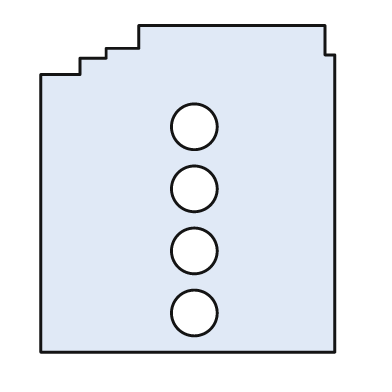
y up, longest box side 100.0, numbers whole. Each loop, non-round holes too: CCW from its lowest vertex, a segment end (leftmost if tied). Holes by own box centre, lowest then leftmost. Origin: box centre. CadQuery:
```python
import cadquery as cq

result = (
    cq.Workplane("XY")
    .moveTo(-45.0, -50.0)
    .lineTo(45.0, -50.0)
    .lineTo(45.0, 41.0)
    .lineTo(42.0, 41.0)
    .lineTo(42.0, 50.0)
    .lineTo(-15.0, 50.0)
    .lineTo(-15.0, 43.0)
    .lineTo(-25.0, 43.0)
    .lineTo(-25.0, 40.0)
    .lineTo(-33.0, 40.0)
    .lineTo(-33.0, 35.0)
    .lineTo(-45.0, 35.0)
    .close()
    .moveTo(2.0, -38.0)
    .circle(7.0)
    .moveTo(2.0, -19.0)
    .circle(7.0)
    .moveTo(2.0, 0.0)
    .circle(7.0)
    .moveTo(2.0, 19.0)
    .circle(7.0)
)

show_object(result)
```